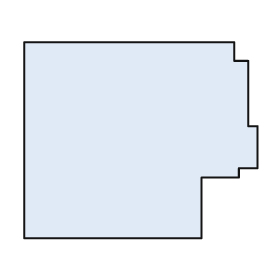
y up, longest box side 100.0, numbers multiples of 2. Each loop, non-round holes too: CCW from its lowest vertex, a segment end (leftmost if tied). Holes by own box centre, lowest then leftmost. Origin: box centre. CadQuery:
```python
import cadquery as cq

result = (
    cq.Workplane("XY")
    .moveTo(-50.0, -42.0)
    .lineTo(26.0, -42.0)
    .lineTo(26.0, -16.0)
    .lineTo(42.0, -16.0)
    .lineTo(42.0, -12.0)
    .lineTo(50.0, -12.0)
    .lineTo(50.0, 6.0)
    .lineTo(46.0, 6.0)
    .lineTo(46.0, 34.0)
    .lineTo(40.0, 34.0)
    .lineTo(40.0, 42.0)
    .lineTo(-50.0, 42.0)
    .close()
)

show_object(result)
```